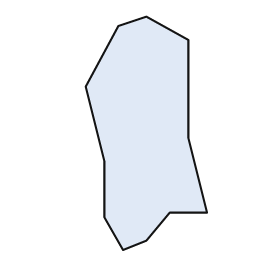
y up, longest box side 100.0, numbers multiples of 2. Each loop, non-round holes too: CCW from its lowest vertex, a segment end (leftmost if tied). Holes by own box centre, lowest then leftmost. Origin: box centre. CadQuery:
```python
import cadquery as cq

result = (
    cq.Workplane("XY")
    .moveTo(-10.0, -50.0)
    .lineTo(0.0, -46.0)
    .lineTo(10.0, -34.0)
    .lineTo(26.0, -34.0)
    .lineTo(18.0, -2.0)
    .lineTo(18.0, 40.0)
    .lineTo(0.0, 50.0)
    .lineTo(-12.0, 46.0)
    .lineTo(-26.0, 20.0)
    .lineTo(-18.0, -12.0)
    .lineTo(-18.0, -36.0)
    .close()
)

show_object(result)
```